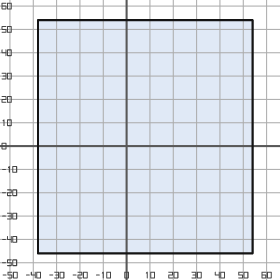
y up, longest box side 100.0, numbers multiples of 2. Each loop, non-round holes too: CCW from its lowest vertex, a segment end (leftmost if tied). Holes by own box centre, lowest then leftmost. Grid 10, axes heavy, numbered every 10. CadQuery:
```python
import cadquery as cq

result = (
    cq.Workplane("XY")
    .moveTo(-38.0, -46.0)
    .lineTo(54.0, -46.0)
    .lineTo(54.0, 54.0)
    .lineTo(-38.0, 54.0)
    .close()
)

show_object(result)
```